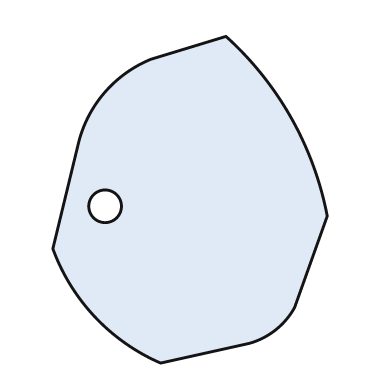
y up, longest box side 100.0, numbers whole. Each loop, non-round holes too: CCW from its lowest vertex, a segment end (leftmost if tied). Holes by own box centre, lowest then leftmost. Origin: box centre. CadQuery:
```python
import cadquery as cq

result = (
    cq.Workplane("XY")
    .moveTo(-9.0, -50.0)
    .lineTo(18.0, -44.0)
    .threePointArc((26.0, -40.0), (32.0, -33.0))
    .lineTo(42.0, -5.0)
    .threePointArc((31.0, 25.0), (11.0, 50.0))
    .lineTo(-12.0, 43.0)
    .threePointArc((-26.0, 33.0), (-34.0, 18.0))
    .lineTo(-42.0, -15.0)
    .threePointArc((-29.0, -36.0), (-9.0, -50.0))
    .close()
    .moveTo(-26.0, -2.0)
    .circle(5.0)
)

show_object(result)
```